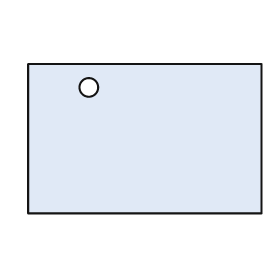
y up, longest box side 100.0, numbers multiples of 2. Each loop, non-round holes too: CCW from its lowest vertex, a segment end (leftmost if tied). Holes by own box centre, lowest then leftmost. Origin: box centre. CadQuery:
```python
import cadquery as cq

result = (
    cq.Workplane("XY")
    .moveTo(-50.0, -32.0)
    .lineTo(50.0, -32.0)
    .lineTo(50.0, 32.0)
    .lineTo(-50.0, 32.0)
    .close()
    .moveTo(-24.0, 22.0)
    .circle(4.0)
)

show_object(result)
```